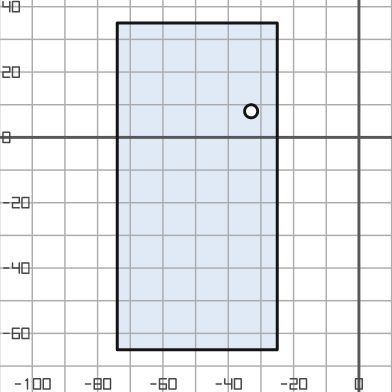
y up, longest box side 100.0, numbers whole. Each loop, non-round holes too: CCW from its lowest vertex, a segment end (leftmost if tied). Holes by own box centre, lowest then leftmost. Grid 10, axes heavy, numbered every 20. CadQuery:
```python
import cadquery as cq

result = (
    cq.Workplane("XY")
    .moveTo(-74.0, -65.0)
    .lineTo(-25.0, -65.0)
    .lineTo(-25.0, 35.0)
    .lineTo(-74.0, 35.0)
    .close()
    .moveTo(-33.0, 8.0)
    .circle(2.0)
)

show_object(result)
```